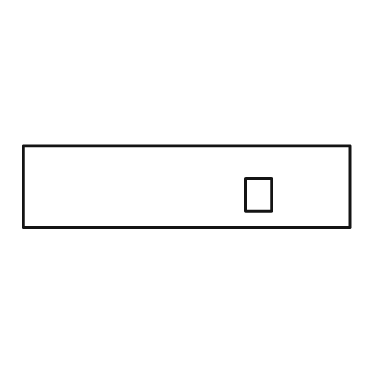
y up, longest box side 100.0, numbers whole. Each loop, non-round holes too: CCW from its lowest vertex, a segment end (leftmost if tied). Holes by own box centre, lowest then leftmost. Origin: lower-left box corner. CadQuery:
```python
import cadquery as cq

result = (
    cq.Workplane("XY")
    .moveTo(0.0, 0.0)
    .lineTo(100.0, 0.0)
    .lineTo(100.0, 25.0)
    .lineTo(0.0, 25.0)
    .close()
    .moveTo(68.0, 5.0)
    .lineTo(76.0, 5.0)
    .lineTo(76.0, 15.0)
    .lineTo(68.0, 15.0)
    .close()
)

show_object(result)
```